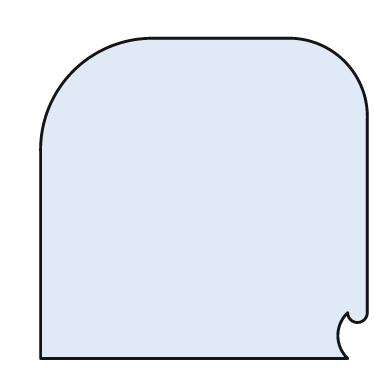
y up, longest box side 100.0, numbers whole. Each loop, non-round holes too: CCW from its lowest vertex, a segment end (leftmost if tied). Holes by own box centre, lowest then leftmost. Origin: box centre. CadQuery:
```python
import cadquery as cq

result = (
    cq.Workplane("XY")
    .moveTo(-50.0, -49.0)
    .lineTo(44.0, -49.0)
    .threePointArc((41.0, -42.0), (44.0, -35.0))
    .threePointArc((47.0, -38.0), (50.0, -35.0))
    .lineTo(50.0, 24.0)
    .threePointArc((43.0, 42.0), (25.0, 49.0))
    .lineTo(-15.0, 49.0)
    .threePointArc((-40.0, 39.0), (-50.0, 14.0))
    .close()
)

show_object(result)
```